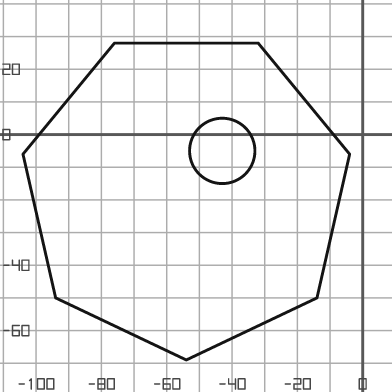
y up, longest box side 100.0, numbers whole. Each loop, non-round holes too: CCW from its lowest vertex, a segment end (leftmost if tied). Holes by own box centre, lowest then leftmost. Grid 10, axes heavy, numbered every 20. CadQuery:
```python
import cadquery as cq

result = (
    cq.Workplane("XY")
    .moveTo(-54.0, -69.0)
    .lineTo(-14.0, -50.0)
    .lineTo(-4.0, -6.0)
    .lineTo(-32.0, 28.0)
    .lineTo(-76.0, 28.0)
    .lineTo(-104.0, -6.0)
    .lineTo(-94.0, -50.0)
    .close()
    .moveTo(-43.0, -5.0)
    .circle(10.0)
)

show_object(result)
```